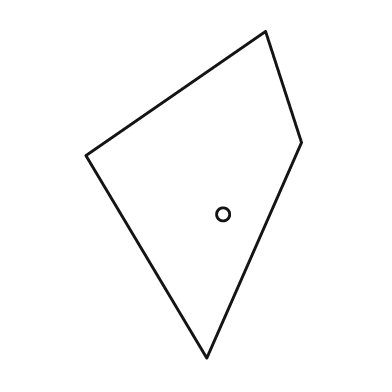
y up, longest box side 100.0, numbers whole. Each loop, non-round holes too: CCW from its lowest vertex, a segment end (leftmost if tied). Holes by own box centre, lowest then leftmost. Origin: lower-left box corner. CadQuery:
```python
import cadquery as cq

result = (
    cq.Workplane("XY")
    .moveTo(37.0, 0.0)
    .lineTo(66.0, 66.0)
    .lineTo(55.0, 100.0)
    .lineTo(0.0, 62.0)
    .close()
    .moveTo(42.0, 44.0)
    .circle(2.0)
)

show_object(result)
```